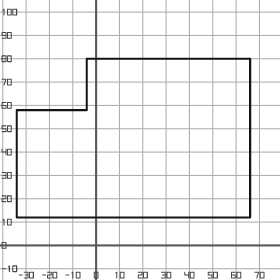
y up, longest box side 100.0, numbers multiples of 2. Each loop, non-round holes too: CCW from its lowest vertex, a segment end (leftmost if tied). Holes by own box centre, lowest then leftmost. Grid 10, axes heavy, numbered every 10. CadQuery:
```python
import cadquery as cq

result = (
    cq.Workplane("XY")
    .moveTo(-34.0, 12.0)
    .lineTo(66.0, 12.0)
    .lineTo(66.0, 80.0)
    .lineTo(-4.0, 80.0)
    .lineTo(-4.0, 58.0)
    .lineTo(-34.0, 58.0)
    .close()
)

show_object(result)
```